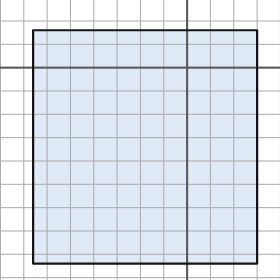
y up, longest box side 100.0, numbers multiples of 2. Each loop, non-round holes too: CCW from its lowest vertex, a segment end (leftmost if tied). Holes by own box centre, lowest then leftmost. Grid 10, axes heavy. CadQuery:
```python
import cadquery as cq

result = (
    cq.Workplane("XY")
    .moveTo(-66.0, -84.0)
    .lineTo(30.0, -84.0)
    .lineTo(30.0, 16.0)
    .lineTo(-66.0, 16.0)
    .close()
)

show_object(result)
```